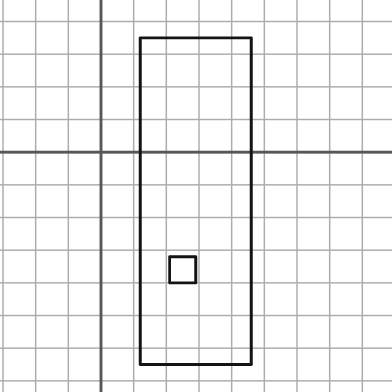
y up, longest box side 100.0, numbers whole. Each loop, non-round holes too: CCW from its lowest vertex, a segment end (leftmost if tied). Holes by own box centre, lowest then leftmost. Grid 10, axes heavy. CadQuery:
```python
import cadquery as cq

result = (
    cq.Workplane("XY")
    .moveTo(12.0, -65.0)
    .lineTo(46.0, -65.0)
    .lineTo(46.0, 35.0)
    .lineTo(12.0, 35.0)
    .close()
    .moveTo(21.0, -40.0)
    .lineTo(29.0, -40.0)
    .lineTo(29.0, -32.0)
    .lineTo(21.0, -32.0)
    .close()
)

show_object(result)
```